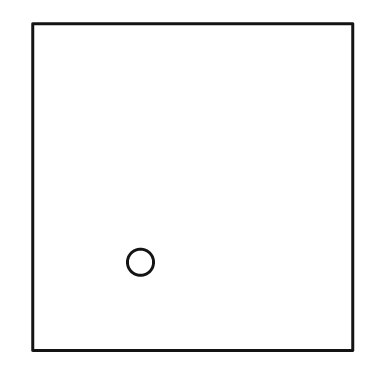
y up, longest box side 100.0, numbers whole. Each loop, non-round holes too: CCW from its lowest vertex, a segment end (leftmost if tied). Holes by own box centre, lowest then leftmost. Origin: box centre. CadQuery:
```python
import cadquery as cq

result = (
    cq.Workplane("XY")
    .moveTo(-49.0, -50.0)
    .lineTo(49.0, -50.0)
    .lineTo(49.0, 50.0)
    .lineTo(-49.0, 50.0)
    .close()
    .moveTo(-16.0, -23.0)
    .circle(4.0)
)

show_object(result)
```